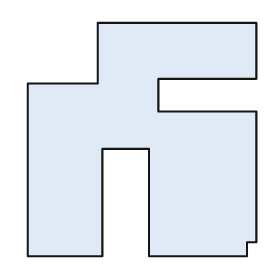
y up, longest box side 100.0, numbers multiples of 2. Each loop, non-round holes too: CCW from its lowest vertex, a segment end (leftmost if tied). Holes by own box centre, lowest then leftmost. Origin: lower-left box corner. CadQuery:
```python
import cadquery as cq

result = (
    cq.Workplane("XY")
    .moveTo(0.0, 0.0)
    .lineTo(32.0, 0.0)
    .lineTo(32.0, 46.0)
    .lineTo(52.0, 46.0)
    .lineTo(52.0, 0.0)
    .lineTo(94.0, 0.0)
    .lineTo(94.0, 6.0)
    .lineTo(98.0, 6.0)
    .lineTo(98.0, 62.0)
    .lineTo(56.0, 62.0)
    .lineTo(56.0, 76.0)
    .lineTo(98.0, 76.0)
    .lineTo(98.0, 100.0)
    .lineTo(30.0, 100.0)
    .lineTo(30.0, 74.0)
    .lineTo(0.0, 74.0)
    .close()
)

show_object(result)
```